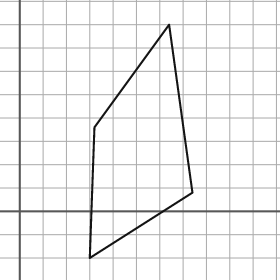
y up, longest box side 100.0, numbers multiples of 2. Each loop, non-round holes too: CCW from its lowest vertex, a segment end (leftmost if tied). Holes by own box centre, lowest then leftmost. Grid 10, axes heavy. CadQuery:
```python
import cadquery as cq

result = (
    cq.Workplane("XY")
    .moveTo(30.0, -20.0)
    .lineTo(74.0, 8.0)
    .lineTo(64.0, 80.0)
    .lineTo(32.0, 36.0)
    .close()
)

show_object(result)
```